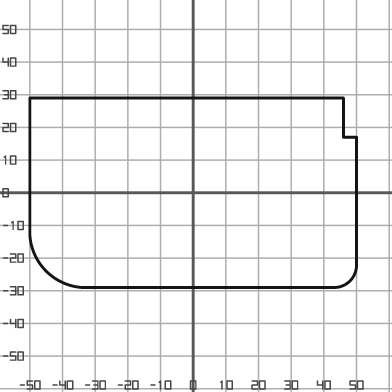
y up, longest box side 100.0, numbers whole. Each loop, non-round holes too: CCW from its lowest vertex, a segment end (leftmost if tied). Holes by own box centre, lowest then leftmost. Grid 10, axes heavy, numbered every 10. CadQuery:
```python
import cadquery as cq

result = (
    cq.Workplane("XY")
    .moveTo(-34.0, -29.0)
    .lineTo(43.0, -29.0)
    .threePointArc((48.0, -27.0), (50.0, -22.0))
    .lineTo(50.0, 17.0)
    .lineTo(46.0, 17.0)
    .lineTo(46.0, 29.0)
    .lineTo(-50.0, 29.0)
    .lineTo(-50.0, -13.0)
    .threePointArc((-45.0, -24.0), (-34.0, -29.0))
    .close()
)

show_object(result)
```